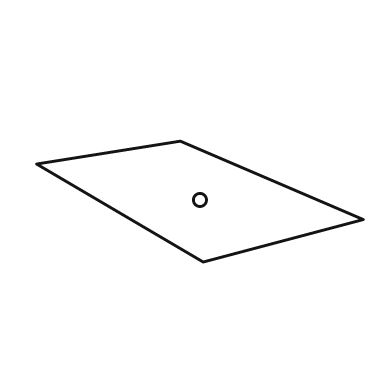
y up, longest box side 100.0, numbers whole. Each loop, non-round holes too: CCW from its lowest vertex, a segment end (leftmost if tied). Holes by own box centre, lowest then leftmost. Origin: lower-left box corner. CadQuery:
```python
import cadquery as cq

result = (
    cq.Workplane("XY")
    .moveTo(51.0, 0.0)
    .lineTo(100.0, 13.0)
    .lineTo(44.0, 37.0)
    .lineTo(0.0, 30.0)
    .close()
    .moveTo(50.0, 19.0)
    .circle(2.0)
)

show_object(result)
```